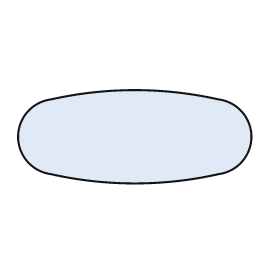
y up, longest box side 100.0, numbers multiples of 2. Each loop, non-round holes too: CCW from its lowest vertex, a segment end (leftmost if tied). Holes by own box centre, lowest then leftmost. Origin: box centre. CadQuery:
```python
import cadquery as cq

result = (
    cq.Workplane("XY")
    .moveTo(-36.0, -16.0)
    .threePointArc((0.0, -20.0), (36.0, -16.0))
    .threePointArc((50.0, 0.0), (36.0, 16.0))
    .threePointArc((0.0, 20.0), (-36.0, 16.0))
    .threePointArc((-50.0, 0.0), (-36.0, -16.0))
    .close()
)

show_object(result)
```